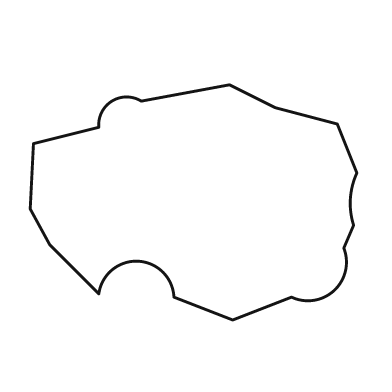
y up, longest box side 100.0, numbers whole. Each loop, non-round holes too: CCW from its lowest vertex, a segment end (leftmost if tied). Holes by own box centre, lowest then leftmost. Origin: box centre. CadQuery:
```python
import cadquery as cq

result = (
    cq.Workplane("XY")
    .moveTo(12.0, -36.0)
    .lineTo(30.0, -29.0)
    .threePointArc((43.0, -27.0), (46.0, -14.0))
    .lineTo(49.0, -7.0)
    .threePointArc((48.0, 1.0), (50.0, 9.0))
    .lineTo(44.0, 24.0)
    .lineTo(25.0, 29.0)
    .lineTo(11.0, 36.0)
    .lineTo(-16.0, 31.0)
    .threePointArc((-25.0, 31.0), (-29.0, 23.0))
    .lineTo(-49.0, 18.0)
    .lineTo(-50.0, -2.0)
    .lineTo(-44.0, -13.0)
    .lineTo(-29.0, -28.0)
    .threePointArc((-17.0, -18.0), (-6.0, -29.0))
    .close()
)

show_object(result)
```